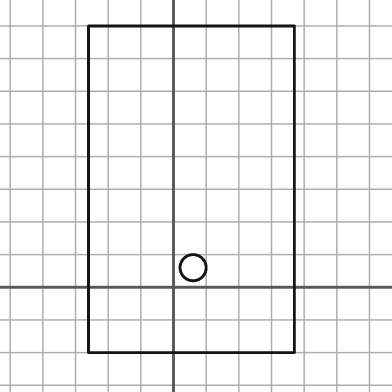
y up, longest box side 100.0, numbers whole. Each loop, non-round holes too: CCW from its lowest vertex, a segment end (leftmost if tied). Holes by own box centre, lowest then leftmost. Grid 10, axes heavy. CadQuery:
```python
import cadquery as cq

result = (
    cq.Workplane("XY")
    .moveTo(-26.0, -20.0)
    .lineTo(37.0, -20.0)
    .lineTo(37.0, 80.0)
    .lineTo(-26.0, 80.0)
    .close()
    .moveTo(6.0, 6.0)
    .circle(4.0)
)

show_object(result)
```